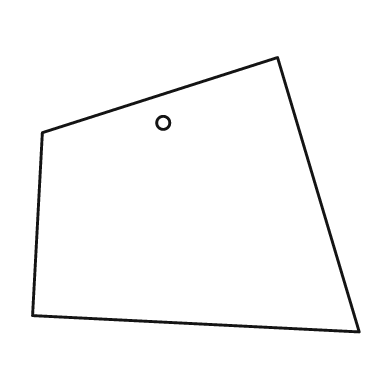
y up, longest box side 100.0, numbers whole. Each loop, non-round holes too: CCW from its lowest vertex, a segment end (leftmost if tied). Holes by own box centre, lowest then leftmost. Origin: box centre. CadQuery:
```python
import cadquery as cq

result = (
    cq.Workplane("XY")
    .moveTo(50.0, -42.0)
    .lineTo(25.0, 42.0)
    .lineTo(-47.0, 19.0)
    .lineTo(-50.0, -37.0)
    .close()
    .moveTo(-10.0, 22.0)
    .circle(2.0)
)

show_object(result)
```